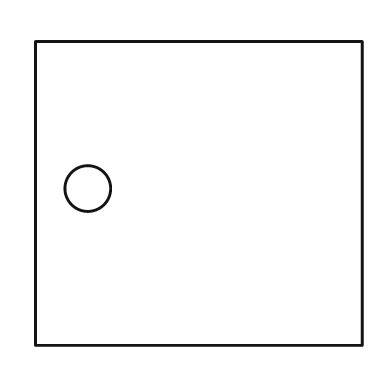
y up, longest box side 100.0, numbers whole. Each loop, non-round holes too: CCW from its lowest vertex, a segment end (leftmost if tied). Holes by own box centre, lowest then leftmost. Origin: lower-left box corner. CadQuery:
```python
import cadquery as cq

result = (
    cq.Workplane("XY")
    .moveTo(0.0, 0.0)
    .lineTo(100.0, 0.0)
    .lineTo(100.0, 93.0)
    .lineTo(0.0, 93.0)
    .close()
    .moveTo(16.0, 48.0)
    .circle(7.0)
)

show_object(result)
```